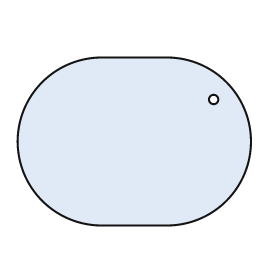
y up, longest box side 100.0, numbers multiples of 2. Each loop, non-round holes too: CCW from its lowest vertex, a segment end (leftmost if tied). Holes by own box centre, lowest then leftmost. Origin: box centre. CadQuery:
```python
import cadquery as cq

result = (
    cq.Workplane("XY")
    .moveTo(-14.0, -36.0)
    .lineTo(14.0, -36.0)
    .threePointArc((50.0, 0.0), (14.0, 36.0))
    .lineTo(-14.0, 36.0)
    .threePointArc((-50.0, 0.0), (-14.0, -36.0))
    .close()
    .moveTo(34.0, 18.0)
    .circle(2.0)
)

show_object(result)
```